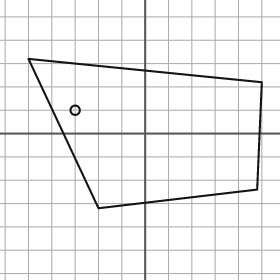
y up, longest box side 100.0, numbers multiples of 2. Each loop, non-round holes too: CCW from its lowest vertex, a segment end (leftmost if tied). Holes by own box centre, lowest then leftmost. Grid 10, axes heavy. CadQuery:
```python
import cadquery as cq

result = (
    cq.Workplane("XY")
    .moveTo(-20.0, -32.0)
    .lineTo(48.0, -24.0)
    .lineTo(50.0, 22.0)
    .lineTo(-50.0, 32.0)
    .close()
    .moveTo(-30.0, 10.0)
    .circle(2.0)
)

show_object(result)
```